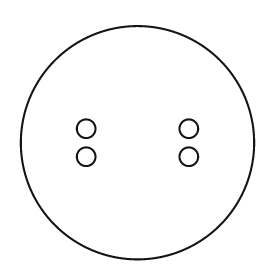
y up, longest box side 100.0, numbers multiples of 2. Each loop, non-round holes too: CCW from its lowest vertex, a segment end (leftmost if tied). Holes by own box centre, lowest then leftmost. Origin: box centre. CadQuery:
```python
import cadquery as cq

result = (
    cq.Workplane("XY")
    .moveTo(0.0, 0.0)
    .circle(50.0)
    .moveTo(-22.0, -6.0)
    .circle(4.0)
    .moveTo(22.0, -6.0)
    .circle(4.0)
    .moveTo(-22.0, 6.0)
    .circle(4.0)
    .moveTo(22.0, 6.0)
    .circle(4.0)
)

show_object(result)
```